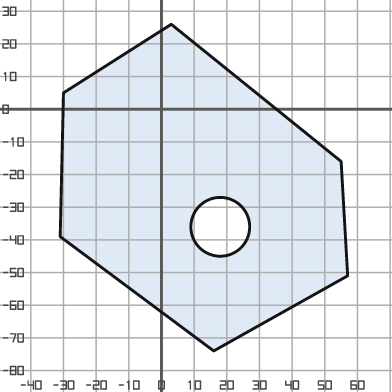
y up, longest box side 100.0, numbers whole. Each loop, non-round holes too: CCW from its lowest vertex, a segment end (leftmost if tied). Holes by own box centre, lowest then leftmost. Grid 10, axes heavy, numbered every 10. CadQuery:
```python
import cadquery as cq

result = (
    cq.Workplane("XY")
    .moveTo(16.0, -74.0)
    .lineTo(57.0, -51.0)
    .lineTo(55.0, -16.0)
    .lineTo(3.0, 26.0)
    .lineTo(-30.0, 5.0)
    .lineTo(-31.0, -39.0)
    .close()
    .moveTo(18.0, -36.0)
    .circle(9.0)
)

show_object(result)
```